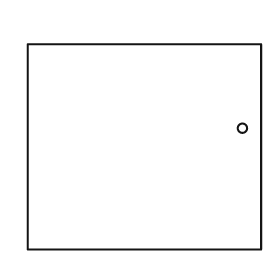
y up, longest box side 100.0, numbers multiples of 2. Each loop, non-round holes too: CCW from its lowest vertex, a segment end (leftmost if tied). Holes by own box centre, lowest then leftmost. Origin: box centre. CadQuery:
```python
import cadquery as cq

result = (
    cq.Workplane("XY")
    .moveTo(-50.0, -44.0)
    .lineTo(50.0, -44.0)
    .lineTo(50.0, 44.0)
    .lineTo(-50.0, 44.0)
    .close()
    .moveTo(42.0, 8.0)
    .circle(2.0)
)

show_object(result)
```